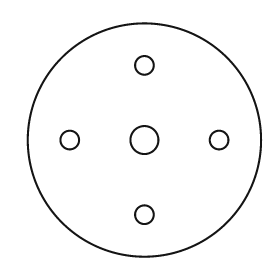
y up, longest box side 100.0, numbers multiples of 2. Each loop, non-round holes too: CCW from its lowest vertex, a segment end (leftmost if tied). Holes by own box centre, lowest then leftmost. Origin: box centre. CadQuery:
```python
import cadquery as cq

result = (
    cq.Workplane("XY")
    .moveTo(0.0, 0.0)
    .circle(50.0)
    .moveTo(0.0, -32.0)
    .circle(4.0)
    .moveTo(-32.0, 0.0)
    .circle(4.0)
    .moveTo(0.0, 0.0)
    .circle(6.0)
    .moveTo(32.0, 0.0)
    .circle(4.0)
    .moveTo(0.0, 32.0)
    .circle(4.0)
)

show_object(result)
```